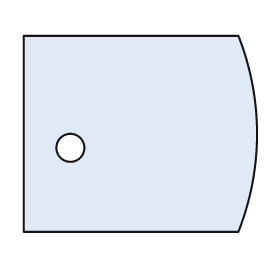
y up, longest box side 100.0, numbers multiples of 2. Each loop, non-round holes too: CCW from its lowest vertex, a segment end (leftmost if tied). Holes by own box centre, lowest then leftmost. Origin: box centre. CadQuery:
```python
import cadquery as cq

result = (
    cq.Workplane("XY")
    .moveTo(-50.0, -42.0)
    .lineTo(42.0, -42.0)
    .threePointArc((50.0, 0.0), (42.0, 42.0))
    .lineTo(-50.0, 42.0)
    .close()
    .moveTo(-30.0, -6.0)
    .circle(6.0)
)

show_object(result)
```